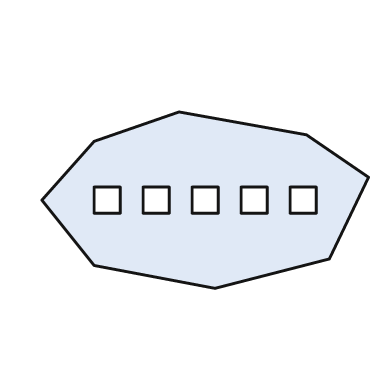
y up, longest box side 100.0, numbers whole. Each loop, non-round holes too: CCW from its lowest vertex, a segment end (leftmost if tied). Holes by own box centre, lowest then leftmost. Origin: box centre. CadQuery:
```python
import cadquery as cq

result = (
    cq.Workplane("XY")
    .moveTo(3.0, -27.0)
    .lineTo(38.0, -18.0)
    .lineTo(50.0, 7.0)
    .lineTo(31.0, 20.0)
    .lineTo(-8.0, 27.0)
    .lineTo(-34.0, 18.0)
    .lineTo(-50.0, 0.0)
    .lineTo(-34.0, -20.0)
    .close()
    .moveTo(-34.0, -4.0)
    .lineTo(-26.0, -4.0)
    .lineTo(-26.0, 4.0)
    .lineTo(-34.0, 4.0)
    .close()
    .moveTo(-19.0, -4.0)
    .lineTo(-11.0, -4.0)
    .lineTo(-11.0, 4.0)
    .lineTo(-19.0, 4.0)
    .close()
    .moveTo(-4.0, -4.0)
    .lineTo(4.0, -4.0)
    .lineTo(4.0, 4.0)
    .lineTo(-4.0, 4.0)
    .close()
    .moveTo(11.0, -4.0)
    .lineTo(19.0, -4.0)
    .lineTo(19.0, 4.0)
    .lineTo(11.0, 4.0)
    .close()
    .moveTo(26.0, -4.0)
    .lineTo(34.0, -4.0)
    .lineTo(34.0, 4.0)
    .lineTo(26.0, 4.0)
    .close()
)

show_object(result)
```